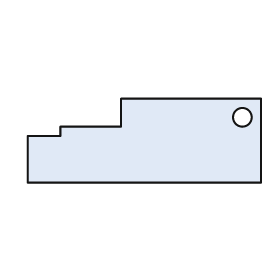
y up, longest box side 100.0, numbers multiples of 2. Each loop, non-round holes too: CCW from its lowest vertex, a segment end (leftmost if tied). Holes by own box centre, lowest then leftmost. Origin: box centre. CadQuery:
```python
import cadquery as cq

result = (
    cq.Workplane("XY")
    .moveTo(-50.0, -18.0)
    .lineTo(50.0, -18.0)
    .lineTo(50.0, 18.0)
    .lineTo(-10.0, 18.0)
    .lineTo(-10.0, 6.0)
    .lineTo(-36.0, 6.0)
    .lineTo(-36.0, 2.0)
    .lineTo(-50.0, 2.0)
    .close()
    .moveTo(42.0, 10.0)
    .circle(4.0)
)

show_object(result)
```